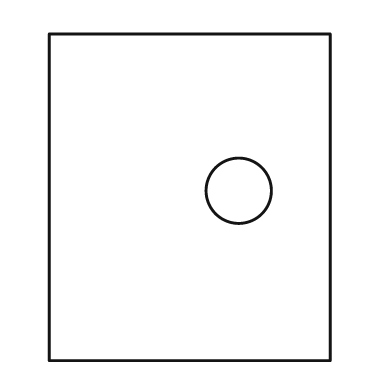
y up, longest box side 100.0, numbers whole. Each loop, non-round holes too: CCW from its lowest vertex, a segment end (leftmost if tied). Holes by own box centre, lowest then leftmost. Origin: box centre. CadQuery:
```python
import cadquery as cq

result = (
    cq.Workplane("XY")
    .moveTo(-43.0, -50.0)
    .lineTo(43.0, -50.0)
    .lineTo(43.0, 50.0)
    .lineTo(-43.0, 50.0)
    .close()
    .moveTo(15.0, 2.0)
    .circle(10.0)
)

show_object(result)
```